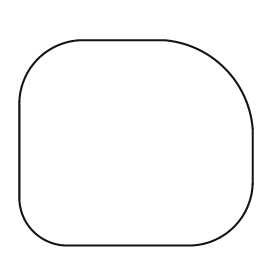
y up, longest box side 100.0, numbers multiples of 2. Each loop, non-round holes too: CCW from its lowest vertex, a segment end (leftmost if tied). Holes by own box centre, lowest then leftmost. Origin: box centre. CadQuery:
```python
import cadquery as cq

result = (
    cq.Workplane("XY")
    .moveTo(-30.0, -44.0)
    .lineTo(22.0, -44.0)
    .threePointArc((42.0, -36.0), (50.0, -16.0))
    .lineTo(50.0, 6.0)
    .threePointArc((38.0, 32.0), (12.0, 44.0))
    .lineTo(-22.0, 44.0)
    .threePointArc((-42.0, 36.0), (-50.0, 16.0))
    .lineTo(-50.0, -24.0)
    .threePointArc((-44.0, -38.0), (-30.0, -44.0))
    .close()
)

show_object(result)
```